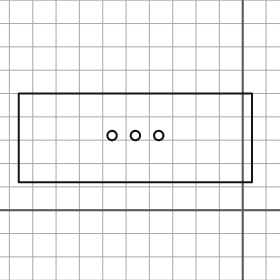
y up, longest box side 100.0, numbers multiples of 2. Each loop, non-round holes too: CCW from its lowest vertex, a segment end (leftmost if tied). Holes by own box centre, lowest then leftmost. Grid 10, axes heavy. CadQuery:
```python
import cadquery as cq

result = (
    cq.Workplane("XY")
    .moveTo(-96.0, 12.0)
    .lineTo(4.0, 12.0)
    .lineTo(4.0, 50.0)
    .lineTo(-96.0, 50.0)
    .close()
    .moveTo(-56.0, 32.0)
    .circle(2.0)
    .moveTo(-46.0, 32.0)
    .circle(2.0)
    .moveTo(-36.0, 32.0)
    .circle(2.0)
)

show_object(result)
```